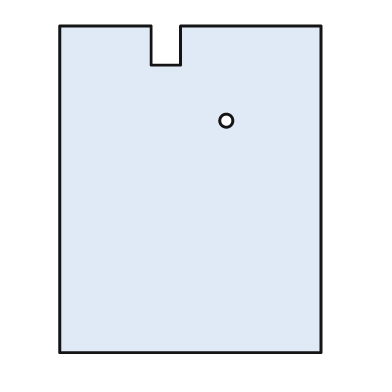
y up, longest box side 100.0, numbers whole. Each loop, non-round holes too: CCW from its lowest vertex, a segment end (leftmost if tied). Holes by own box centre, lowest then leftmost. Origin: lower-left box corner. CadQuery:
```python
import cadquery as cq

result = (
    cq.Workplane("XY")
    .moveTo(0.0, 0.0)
    .lineTo(80.0, 0.0)
    .lineTo(80.0, 100.0)
    .lineTo(37.0, 100.0)
    .lineTo(37.0, 88.0)
    .lineTo(28.0, 88.0)
    .lineTo(28.0, 100.0)
    .lineTo(0.0, 100.0)
    .close()
    .moveTo(51.0, 71.0)
    .circle(2.0)
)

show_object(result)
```